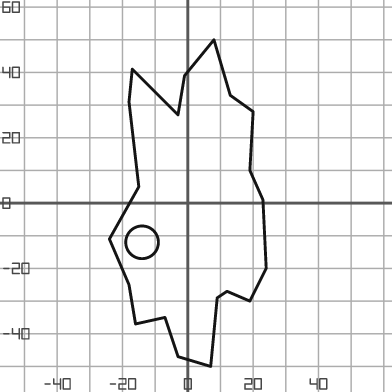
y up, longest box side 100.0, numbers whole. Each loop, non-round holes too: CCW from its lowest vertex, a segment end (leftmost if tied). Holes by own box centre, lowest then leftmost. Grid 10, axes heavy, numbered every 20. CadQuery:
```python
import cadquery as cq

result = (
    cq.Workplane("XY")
    .moveTo(7.0, -50.0)
    .lineTo(9.0, -29.0)
    .lineTo(12.0, -27.0)
    .lineTo(19.0, -30.0)
    .lineTo(24.0, -20.0)
    .lineTo(23.0, 1.0)
    .lineTo(19.0, 10.0)
    .lineTo(20.0, 28.0)
    .lineTo(13.0, 33.0)
    .lineTo(8.0, 50.0)
    .lineTo(-1.0, 39.0)
    .lineTo(-3.0, 27.0)
    .lineTo(-17.0, 41.0)
    .lineTo(-18.0, 31.0)
    .lineTo(-15.0, 5.0)
    .lineTo(-24.0, -11.0)
    .lineTo(-18.0, -25.0)
    .lineTo(-16.0, -37.0)
    .lineTo(-7.0, -35.0)
    .lineTo(-3.0, -47.0)
    .close()
    .moveTo(-14.0, -12.0)
    .circle(5.0)
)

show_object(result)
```